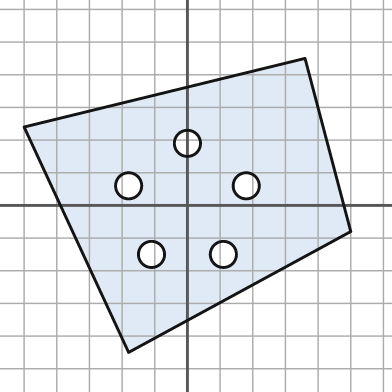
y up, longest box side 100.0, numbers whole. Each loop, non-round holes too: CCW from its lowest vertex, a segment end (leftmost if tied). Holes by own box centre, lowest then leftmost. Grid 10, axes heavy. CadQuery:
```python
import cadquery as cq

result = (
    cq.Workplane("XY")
    .moveTo(-18.0, -45.0)
    .lineTo(50.0, -8.0)
    .lineTo(36.0, 45.0)
    .lineTo(-50.0, 24.0)
    .close()
    .moveTo(-11.0, -15.0)
    .circle(4.0)
    .moveTo(11.0, -15.0)
    .circle(4.0)
    .moveTo(-18.0, 6.0)
    .circle(4.0)
    .moveTo(18.0, 6.0)
    .circle(4.0)
    .moveTo(0.0, 19.0)
    .circle(4.0)
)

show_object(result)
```